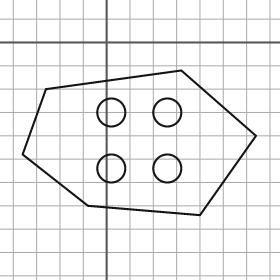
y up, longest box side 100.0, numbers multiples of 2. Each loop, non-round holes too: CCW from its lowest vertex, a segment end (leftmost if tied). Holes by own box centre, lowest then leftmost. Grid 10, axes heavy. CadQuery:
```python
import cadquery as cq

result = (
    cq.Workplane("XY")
    .moveTo(40.0, -74.0)
    .lineTo(64.0, -40.0)
    .lineTo(32.0, -12.0)
    .lineTo(-26.0, -20.0)
    .lineTo(-36.0, -48.0)
    .lineTo(-8.0, -70.0)
    .close()
    .moveTo(2.0, -54.0)
    .circle(6.0)
    .moveTo(26.0, -54.0)
    .circle(6.0)
    .moveTo(2.0, -30.0)
    .circle(6.0)
    .moveTo(26.0, -30.0)
    .circle(6.0)
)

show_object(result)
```